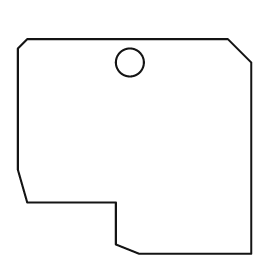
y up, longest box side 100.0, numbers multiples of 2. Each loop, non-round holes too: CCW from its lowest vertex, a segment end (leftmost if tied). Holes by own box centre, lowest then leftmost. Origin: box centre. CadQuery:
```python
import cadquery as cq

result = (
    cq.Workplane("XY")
    .moveTo(2.0, -46.0)
    .lineTo(50.0, -46.0)
    .lineTo(50.0, 36.0)
    .lineTo(40.0, 46.0)
    .lineTo(-46.0, 46.0)
    .lineTo(-50.0, 42.0)
    .lineTo(-50.0, -10.0)
    .lineTo(-46.0, -24.0)
    .lineTo(-8.0, -24.0)
    .lineTo(-8.0, -42.0)
    .close()
    .moveTo(-2.0, 36.0)
    .circle(6.0)
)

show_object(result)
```